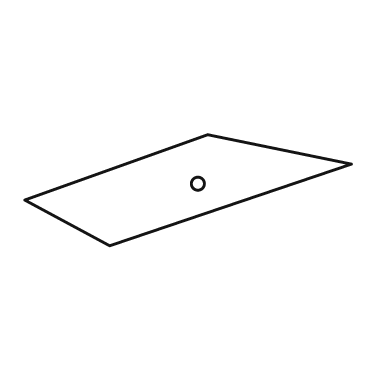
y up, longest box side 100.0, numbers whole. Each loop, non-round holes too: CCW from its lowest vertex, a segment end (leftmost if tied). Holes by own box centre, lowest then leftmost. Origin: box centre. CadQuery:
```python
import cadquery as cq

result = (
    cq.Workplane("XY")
    .moveTo(-24.0, -17.0)
    .lineTo(50.0, 8.0)
    .lineTo(6.0, 17.0)
    .lineTo(-50.0, -3.0)
    .close()
    .moveTo(3.0, 2.0)
    .circle(2.0)
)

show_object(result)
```